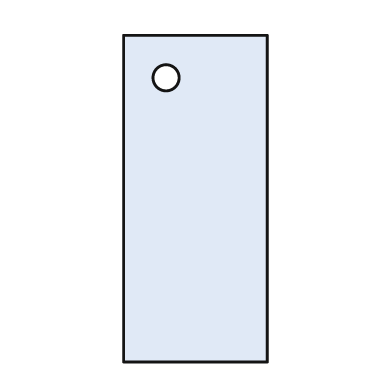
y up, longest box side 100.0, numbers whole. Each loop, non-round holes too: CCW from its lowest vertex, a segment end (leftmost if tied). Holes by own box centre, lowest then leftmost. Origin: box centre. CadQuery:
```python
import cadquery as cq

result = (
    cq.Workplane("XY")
    .moveTo(-22.0, -50.0)
    .lineTo(22.0, -50.0)
    .lineTo(22.0, 50.0)
    .lineTo(-22.0, 50.0)
    .close()
    .moveTo(-9.0, 37.0)
    .circle(4.0)
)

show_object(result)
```